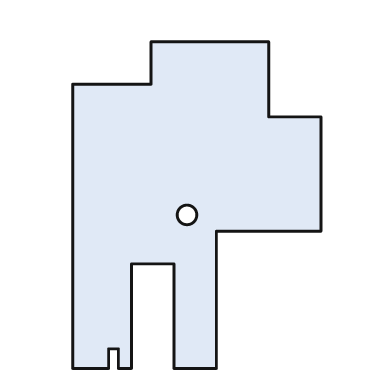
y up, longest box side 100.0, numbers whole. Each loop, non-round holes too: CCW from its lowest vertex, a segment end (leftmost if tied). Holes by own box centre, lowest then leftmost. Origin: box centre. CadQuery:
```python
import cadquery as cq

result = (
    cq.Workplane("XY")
    .moveTo(-38.0, -50.0)
    .lineTo(-27.0, -50.0)
    .lineTo(-27.0, -44.0)
    .lineTo(-24.0, -44.0)
    .lineTo(-24.0, -50.0)
    .lineTo(-20.0, -50.0)
    .lineTo(-20.0, -18.0)
    .lineTo(-7.0, -18.0)
    .lineTo(-7.0, -50.0)
    .lineTo(6.0, -50.0)
    .lineTo(6.0, -8.0)
    .lineTo(38.0, -8.0)
    .lineTo(38.0, 27.0)
    .lineTo(22.0, 27.0)
    .lineTo(22.0, 50.0)
    .lineTo(-14.0, 50.0)
    .lineTo(-14.0, 37.0)
    .lineTo(-38.0, 37.0)
    .close()
    .moveTo(-3.0, -3.0)
    .circle(3.0)
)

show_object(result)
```